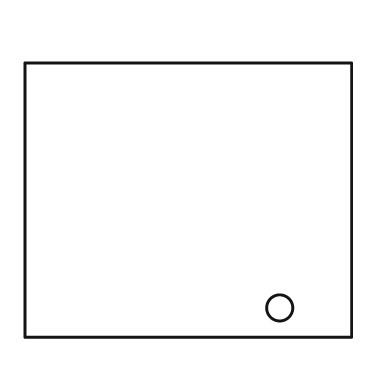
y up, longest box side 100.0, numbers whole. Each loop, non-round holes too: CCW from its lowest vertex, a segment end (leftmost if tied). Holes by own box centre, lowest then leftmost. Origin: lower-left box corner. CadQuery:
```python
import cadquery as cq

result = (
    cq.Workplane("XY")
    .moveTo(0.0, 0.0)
    .lineTo(100.0, 0.0)
    .lineTo(100.0, 84.0)
    .lineTo(0.0, 84.0)
    .close()
    .moveTo(78.0, 9.0)
    .circle(4.0)
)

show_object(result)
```